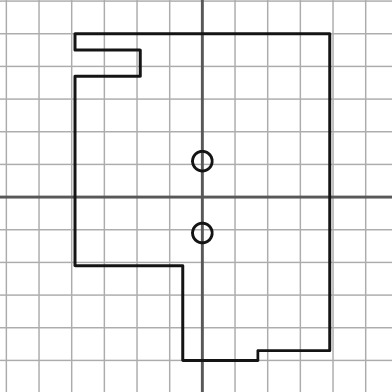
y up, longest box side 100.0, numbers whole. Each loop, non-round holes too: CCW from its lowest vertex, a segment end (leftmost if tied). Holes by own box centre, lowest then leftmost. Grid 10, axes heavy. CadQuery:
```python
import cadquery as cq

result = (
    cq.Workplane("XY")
    .moveTo(-6.0, -50.0)
    .lineTo(17.0, -50.0)
    .lineTo(17.0, -47.0)
    .lineTo(39.0, -47.0)
    .lineTo(39.0, 50.0)
    .lineTo(-39.0, 50.0)
    .lineTo(-39.0, 45.0)
    .lineTo(-19.0, 45.0)
    .lineTo(-19.0, 37.0)
    .lineTo(-39.0, 37.0)
    .lineTo(-39.0, -21.0)
    .lineTo(-6.0, -21.0)
    .close()
    .moveTo(0.0, -11.0)
    .circle(3.0)
    .moveTo(0.0, 11.0)
    .circle(3.0)
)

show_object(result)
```